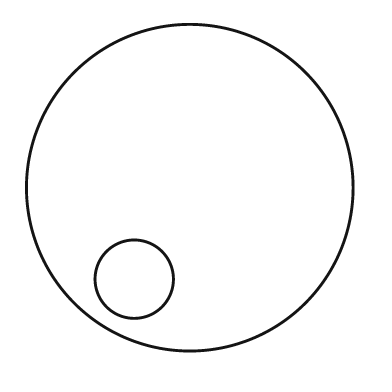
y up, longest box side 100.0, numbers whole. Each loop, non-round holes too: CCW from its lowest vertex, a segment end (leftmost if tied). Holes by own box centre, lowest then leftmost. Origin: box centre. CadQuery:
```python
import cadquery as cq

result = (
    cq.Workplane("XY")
    .moveTo(0.0, 0.0)
    .circle(50.0)
    .moveTo(-17.0, -28.0)
    .circle(12.0)
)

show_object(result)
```